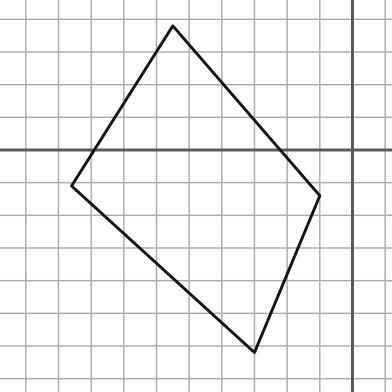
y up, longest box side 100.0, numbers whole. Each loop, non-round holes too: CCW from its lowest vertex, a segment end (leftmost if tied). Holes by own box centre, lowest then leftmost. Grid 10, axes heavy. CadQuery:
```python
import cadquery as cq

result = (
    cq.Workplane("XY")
    .moveTo(-30.0, -62.0)
    .lineTo(-10.0, -14.0)
    .lineTo(-55.0, 38.0)
    .lineTo(-86.0, -11.0)
    .close()
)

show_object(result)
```